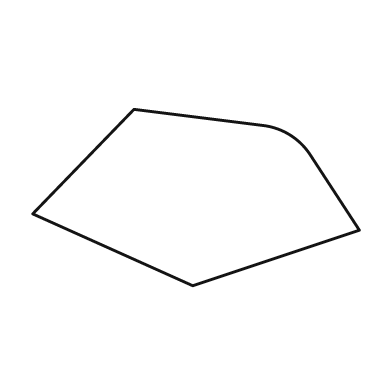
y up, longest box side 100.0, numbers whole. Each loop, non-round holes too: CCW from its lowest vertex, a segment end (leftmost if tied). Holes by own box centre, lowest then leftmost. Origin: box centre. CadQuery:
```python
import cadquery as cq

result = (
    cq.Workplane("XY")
    .moveTo(-1.0, -27.0)
    .lineTo(50.0, -10.0)
    .lineTo(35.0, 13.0)
    .threePointArc((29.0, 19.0), (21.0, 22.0))
    .lineTo(-19.0, 27.0)
    .lineTo(-50.0, -5.0)
    .close()
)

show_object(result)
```